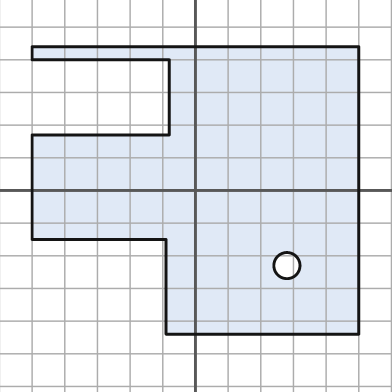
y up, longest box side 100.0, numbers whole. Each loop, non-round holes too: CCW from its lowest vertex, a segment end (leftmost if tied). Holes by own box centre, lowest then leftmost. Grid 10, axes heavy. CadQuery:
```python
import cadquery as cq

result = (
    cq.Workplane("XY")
    .moveTo(-9.0, -44.0)
    .lineTo(50.0, -44.0)
    .lineTo(50.0, 44.0)
    .lineTo(-50.0, 44.0)
    .lineTo(-50.0, 40.0)
    .lineTo(-8.0, 40.0)
    .lineTo(-8.0, 17.0)
    .lineTo(-50.0, 17.0)
    .lineTo(-50.0, -15.0)
    .lineTo(-9.0, -15.0)
    .close()
    .moveTo(28.0, -23.0)
    .circle(4.0)
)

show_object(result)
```